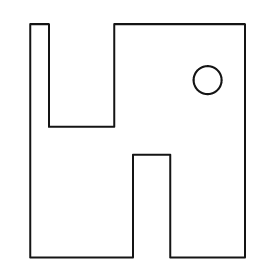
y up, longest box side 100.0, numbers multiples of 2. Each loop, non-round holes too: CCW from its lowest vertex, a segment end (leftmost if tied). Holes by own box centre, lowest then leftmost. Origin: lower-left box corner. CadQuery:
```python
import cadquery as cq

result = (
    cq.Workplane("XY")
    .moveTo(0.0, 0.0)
    .lineTo(44.0, 0.0)
    .lineTo(44.0, 44.0)
    .lineTo(60.0, 44.0)
    .lineTo(60.0, 0.0)
    .lineTo(92.0, 0.0)
    .lineTo(92.0, 100.0)
    .lineTo(36.0, 100.0)
    .lineTo(36.0, 56.0)
    .lineTo(8.0, 56.0)
    .lineTo(8.0, 100.0)
    .lineTo(0.0, 100.0)
    .close()
    .moveTo(76.0, 76.0)
    .circle(6.0)
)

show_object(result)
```